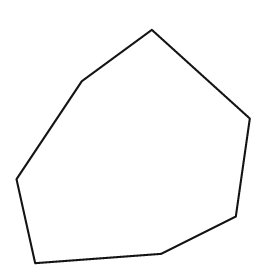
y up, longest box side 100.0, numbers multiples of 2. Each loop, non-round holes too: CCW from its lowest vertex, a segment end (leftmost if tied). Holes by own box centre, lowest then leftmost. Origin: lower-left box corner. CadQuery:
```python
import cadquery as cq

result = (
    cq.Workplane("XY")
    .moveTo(8.0, 0.0)
    .lineTo(62.0, 4.0)
    .lineTo(94.0, 20.0)
    .lineTo(100.0, 62.0)
    .lineTo(58.0, 100.0)
    .lineTo(28.0, 78.0)
    .lineTo(0.0, 36.0)
    .close()
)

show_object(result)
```